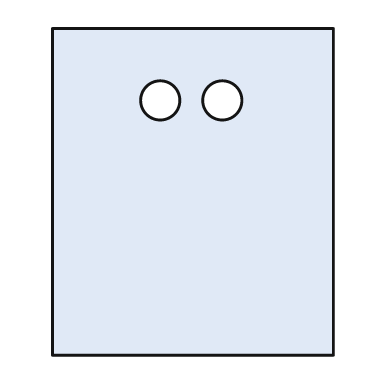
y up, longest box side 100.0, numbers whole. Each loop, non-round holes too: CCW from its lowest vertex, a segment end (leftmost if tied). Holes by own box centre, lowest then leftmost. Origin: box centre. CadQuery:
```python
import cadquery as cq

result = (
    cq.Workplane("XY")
    .moveTo(-43.0, -50.0)
    .lineTo(43.0, -50.0)
    .lineTo(43.0, 50.0)
    .lineTo(-43.0, 50.0)
    .close()
    .moveTo(-10.0, 28.0)
    .circle(6.0)
    .moveTo(9.0, 28.0)
    .circle(6.0)
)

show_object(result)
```